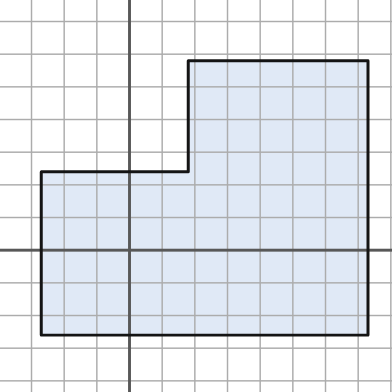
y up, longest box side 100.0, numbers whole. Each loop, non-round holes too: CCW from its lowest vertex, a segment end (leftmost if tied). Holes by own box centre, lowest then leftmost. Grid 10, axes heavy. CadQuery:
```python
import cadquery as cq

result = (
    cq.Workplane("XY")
    .moveTo(-27.0, -26.0)
    .lineTo(73.0, -26.0)
    .lineTo(73.0, 58.0)
    .lineTo(18.0, 58.0)
    .lineTo(18.0, 24.0)
    .lineTo(-27.0, 24.0)
    .close()
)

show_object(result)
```